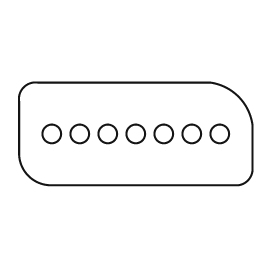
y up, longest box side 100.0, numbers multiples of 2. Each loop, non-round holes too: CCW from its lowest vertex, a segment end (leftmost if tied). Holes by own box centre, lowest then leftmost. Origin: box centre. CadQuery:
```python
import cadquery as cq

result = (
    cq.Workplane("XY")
    .moveTo(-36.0, -22.0)
    .lineTo(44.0, -22.0)
    .threePointArc((48.0, -20.0), (50.0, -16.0))
    .lineTo(50.0, 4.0)
    .threePointArc((44.0, 16.0), (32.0, 22.0))
    .lineTo(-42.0, 22.0)
    .threePointArc((-48.0, 20.0), (-50.0, 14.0))
    .lineTo(-50.0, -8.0)
    .threePointArc((-46.0, -18.0), (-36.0, -22.0))
    .close()
    .moveTo(-36.0, 0.0)
    .circle(4.0)
    .moveTo(-24.0, 0.0)
    .circle(4.0)
    .moveTo(-12.0, 0.0)
    .circle(4.0)
    .moveTo(0.0, 0.0)
    .circle(4.0)
    .moveTo(12.0, 0.0)
    .circle(4.0)
    .moveTo(24.0, 0.0)
    .circle(4.0)
    .moveTo(36.0, 0.0)
    .circle(4.0)
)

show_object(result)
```